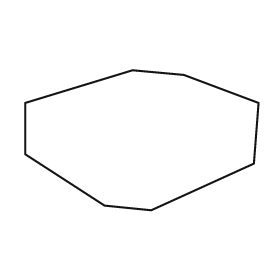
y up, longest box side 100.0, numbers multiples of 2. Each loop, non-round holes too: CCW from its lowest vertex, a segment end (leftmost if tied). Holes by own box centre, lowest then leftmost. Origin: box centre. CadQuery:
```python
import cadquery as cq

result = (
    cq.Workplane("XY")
    .moveTo(4.0, -30.0)
    .lineTo(48.0, -10.0)
    .lineTo(50.0, 16.0)
    .lineTo(18.0, 28.0)
    .lineTo(-4.0, 30.0)
    .lineTo(-50.0, 16.0)
    .lineTo(-50.0, -6.0)
    .lineTo(-16.0, -28.0)
    .close()
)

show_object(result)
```